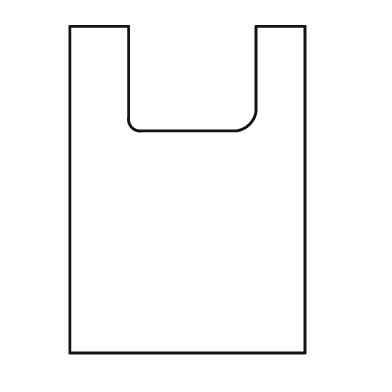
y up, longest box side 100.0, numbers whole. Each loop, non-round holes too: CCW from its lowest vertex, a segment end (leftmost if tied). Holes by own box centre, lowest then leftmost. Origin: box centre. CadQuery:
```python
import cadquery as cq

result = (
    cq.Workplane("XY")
    .moveTo(-36.0, -50.0)
    .lineTo(36.0, -50.0)
    .lineTo(36.0, 50.0)
    .lineTo(21.0, 50.0)
    .lineTo(21.0, 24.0)
    .threePointArc((19.0, 20.0), (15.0, 18.0))
    .lineTo(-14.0, 18.0)
    .threePointArc((-17.0, 19.0), (-18.0, 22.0))
    .lineTo(-18.0, 50.0)
    .lineTo(-36.0, 50.0)
    .close()
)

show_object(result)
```